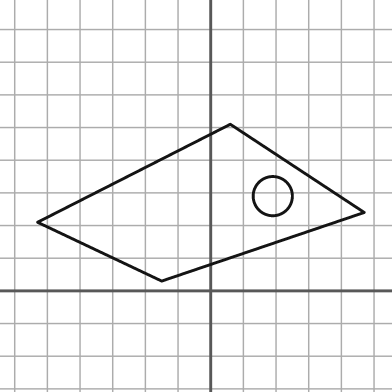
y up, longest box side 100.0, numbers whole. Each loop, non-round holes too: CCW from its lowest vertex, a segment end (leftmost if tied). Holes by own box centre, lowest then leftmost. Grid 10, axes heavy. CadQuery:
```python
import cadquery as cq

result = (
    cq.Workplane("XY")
    .moveTo(-15.0, 3.0)
    .lineTo(47.0, 24.0)
    .lineTo(6.0, 51.0)
    .lineTo(-53.0, 21.0)
    .close()
    .moveTo(19.0, 29.0)
    .circle(6.0)
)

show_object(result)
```